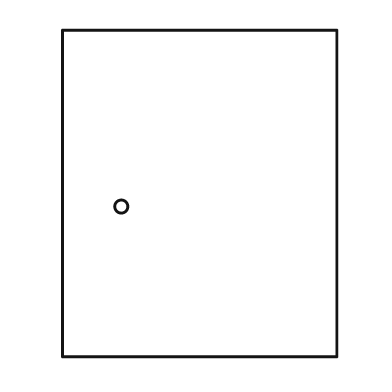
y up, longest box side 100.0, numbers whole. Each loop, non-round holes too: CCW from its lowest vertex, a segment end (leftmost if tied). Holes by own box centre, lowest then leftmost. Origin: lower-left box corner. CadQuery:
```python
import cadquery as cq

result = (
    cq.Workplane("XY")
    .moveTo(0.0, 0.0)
    .lineTo(84.0, 0.0)
    .lineTo(84.0, 100.0)
    .lineTo(0.0, 100.0)
    .close()
    .moveTo(18.0, 46.0)
    .circle(2.0)
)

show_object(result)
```